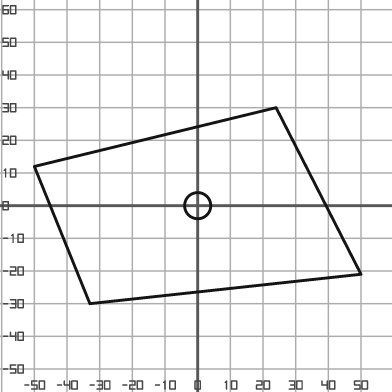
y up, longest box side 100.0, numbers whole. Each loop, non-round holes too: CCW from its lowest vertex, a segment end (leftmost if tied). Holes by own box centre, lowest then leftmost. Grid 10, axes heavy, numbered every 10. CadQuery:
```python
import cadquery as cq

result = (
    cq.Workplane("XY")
    .moveTo(-33.0, -30.0)
    .lineTo(50.0, -21.0)
    .lineTo(24.0, 30.0)
    .lineTo(-50.0, 12.0)
    .close()
    .moveTo(0.0, 0.0)
    .circle(4.0)
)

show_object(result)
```